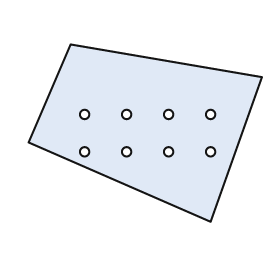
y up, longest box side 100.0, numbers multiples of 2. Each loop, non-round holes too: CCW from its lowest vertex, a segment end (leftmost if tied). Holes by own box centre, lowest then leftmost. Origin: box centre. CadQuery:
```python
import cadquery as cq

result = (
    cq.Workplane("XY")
    .moveTo(28.0, -38.0)
    .lineTo(50.0, 24.0)
    .lineTo(-32.0, 38.0)
    .lineTo(-50.0, -4.0)
    .close()
    .moveTo(-26.0, -8.0)
    .circle(2.0)
    .moveTo(-8.0, -8.0)
    .circle(2.0)
    .moveTo(10.0, -8.0)
    .circle(2.0)
    .moveTo(28.0, -8.0)
    .circle(2.0)
    .moveTo(-26.0, 8.0)
    .circle(2.0)
    .moveTo(-8.0, 8.0)
    .circle(2.0)
    .moveTo(10.0, 8.0)
    .circle(2.0)
    .moveTo(28.0, 8.0)
    .circle(2.0)
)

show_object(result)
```